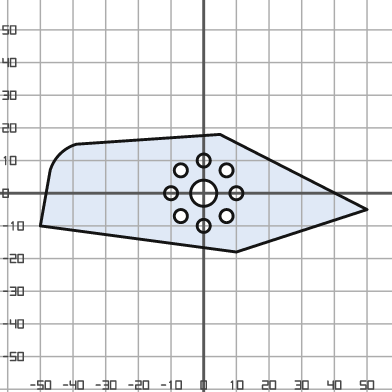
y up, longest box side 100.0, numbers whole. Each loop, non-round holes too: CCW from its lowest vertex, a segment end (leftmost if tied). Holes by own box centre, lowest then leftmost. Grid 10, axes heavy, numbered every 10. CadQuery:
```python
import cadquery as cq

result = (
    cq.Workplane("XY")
    .moveTo(10.0, -18.0)
    .lineTo(50.0, -5.0)
    .lineTo(5.0, 18.0)
    .lineTo(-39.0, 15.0)
    .threePointArc((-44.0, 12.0), (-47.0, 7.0))
    .lineTo(-50.0, -10.0)
    .close()
    .moveTo(0.0, -10.0)
    .circle(2.0)
    .moveTo(-7.0, -7.0)
    .circle(2.0)
    .moveTo(7.0, -7.0)
    .circle(2.0)
    .moveTo(-10.0, 0.0)
    .circle(2.0)
    .moveTo(0.0, 0.0)
    .circle(4.0)
    .moveTo(10.0, 0.0)
    .circle(2.0)
    .moveTo(-7.0, 7.0)
    .circle(2.0)
    .moveTo(7.0, 7.0)
    .circle(2.0)
    .moveTo(0.0, 10.0)
    .circle(2.0)
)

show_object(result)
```